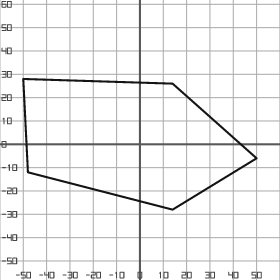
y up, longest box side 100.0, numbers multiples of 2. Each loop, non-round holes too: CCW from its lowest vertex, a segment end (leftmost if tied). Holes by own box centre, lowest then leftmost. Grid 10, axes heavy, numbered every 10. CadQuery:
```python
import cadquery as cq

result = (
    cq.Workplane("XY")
    .moveTo(14.0, -28.0)
    .lineTo(50.0, -6.0)
    .lineTo(14.0, 26.0)
    .lineTo(-50.0, 28.0)
    .lineTo(-48.0, -12.0)
    .close()
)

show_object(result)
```